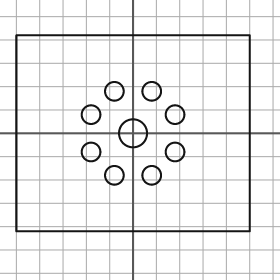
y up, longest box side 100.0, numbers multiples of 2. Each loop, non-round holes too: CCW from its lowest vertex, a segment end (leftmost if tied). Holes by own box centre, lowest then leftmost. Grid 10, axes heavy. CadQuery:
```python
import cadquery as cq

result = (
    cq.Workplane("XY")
    .moveTo(-50.0, -42.0)
    .lineTo(50.0, -42.0)
    .lineTo(50.0, 42.0)
    .lineTo(-50.0, 42.0)
    .close()
    .moveTo(-8.0, -18.0)
    .circle(4.0)
    .moveTo(8.0, -18.0)
    .circle(4.0)
    .moveTo(-18.0, -8.0)
    .circle(4.0)
    .moveTo(18.0, -8.0)
    .circle(4.0)
    .moveTo(0.0, 0.0)
    .circle(6.0)
    .moveTo(-18.0, 8.0)
    .circle(4.0)
    .moveTo(18.0, 8.0)
    .circle(4.0)
    .moveTo(-8.0, 18.0)
    .circle(4.0)
    .moveTo(8.0, 18.0)
    .circle(4.0)
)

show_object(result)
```